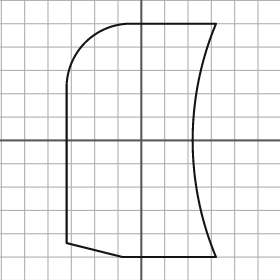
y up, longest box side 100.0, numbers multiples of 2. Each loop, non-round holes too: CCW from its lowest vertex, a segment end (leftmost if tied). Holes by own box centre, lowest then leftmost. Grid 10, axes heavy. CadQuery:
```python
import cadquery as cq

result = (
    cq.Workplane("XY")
    .moveTo(-8.0, -50.0)
    .lineTo(32.0, -50.0)
    .threePointArc((22.0, 0.0), (32.0, 50.0))
    .lineTo(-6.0, 50.0)
    .threePointArc((-24.0, 42.0), (-32.0, 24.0))
    .lineTo(-32.0, -44.0)
    .close()
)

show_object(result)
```